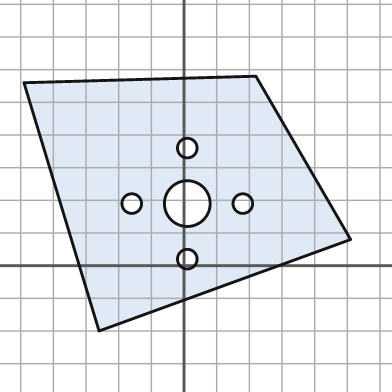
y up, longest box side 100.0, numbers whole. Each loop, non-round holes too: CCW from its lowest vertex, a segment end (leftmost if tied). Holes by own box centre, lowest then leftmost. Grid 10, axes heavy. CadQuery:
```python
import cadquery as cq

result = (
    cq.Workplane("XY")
    .moveTo(-26.0, -20.0)
    .lineTo(51.0, 8.0)
    .lineTo(22.0, 58.0)
    .lineTo(-49.0, 56.0)
    .close()
    .moveTo(1.0, 2.0)
    .circle(3.0)
    .moveTo(-16.0, 19.0)
    .circle(3.0)
    .moveTo(1.0, 19.0)
    .circle(7.0)
    .moveTo(18.0, 19.0)
    .circle(3.0)
    .moveTo(1.0, 36.0)
    .circle(3.0)
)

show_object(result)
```